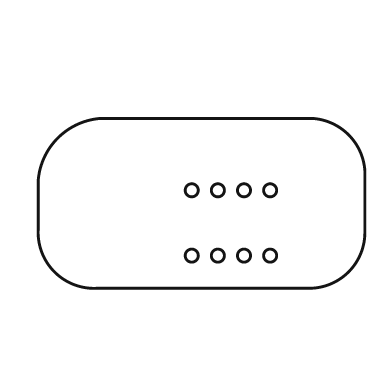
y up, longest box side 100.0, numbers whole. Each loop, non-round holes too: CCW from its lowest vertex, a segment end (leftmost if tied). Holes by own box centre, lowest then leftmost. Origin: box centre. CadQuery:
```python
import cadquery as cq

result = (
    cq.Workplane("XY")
    .moveTo(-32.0, -26.0)
    .lineTo(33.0, -26.0)
    .threePointArc((45.0, -21.0), (50.0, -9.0))
    .lineTo(50.0, 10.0)
    .threePointArc((45.0, 21.0), (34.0, 26.0))
    .lineTo(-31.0, 26.0)
    .threePointArc((-44.0, 20.0), (-50.0, 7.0))
    .lineTo(-50.0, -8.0)
    .threePointArc((-45.0, -21.0), (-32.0, -26.0))
    .close()
    .moveTo(-3.0, -16.0)
    .circle(2.0)
    .moveTo(5.0, -16.0)
    .circle(2.0)
    .moveTo(13.0, -16.0)
    .circle(2.0)
    .moveTo(21.0, -16.0)
    .circle(2.0)
    .moveTo(-3.0, 4.0)
    .circle(2.0)
    .moveTo(5.0, 4.0)
    .circle(2.0)
    .moveTo(13.0, 4.0)
    .circle(2.0)
    .moveTo(21.0, 4.0)
    .circle(2.0)
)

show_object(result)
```